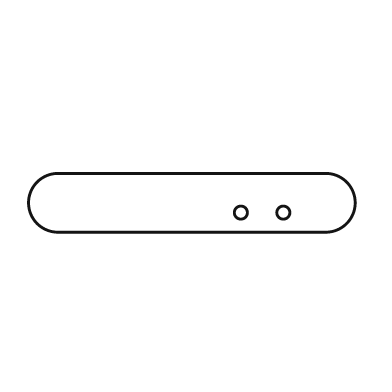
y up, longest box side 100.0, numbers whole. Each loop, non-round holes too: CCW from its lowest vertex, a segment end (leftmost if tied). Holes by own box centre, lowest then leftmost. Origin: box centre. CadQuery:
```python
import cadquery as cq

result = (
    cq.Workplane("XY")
    .moveTo(-41.0, -9.0)
    .lineTo(41.0, -9.0)
    .threePointArc((50.0, 0.0), (41.0, 9.0))
    .lineTo(-41.0, 9.0)
    .threePointArc((-50.0, 0.0), (-41.0, -9.0))
    .close()
    .moveTo(15.0, -3.0)
    .circle(2.0)
    .moveTo(28.0, -3.0)
    .circle(2.0)
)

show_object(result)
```